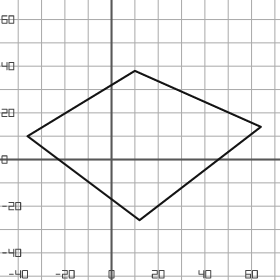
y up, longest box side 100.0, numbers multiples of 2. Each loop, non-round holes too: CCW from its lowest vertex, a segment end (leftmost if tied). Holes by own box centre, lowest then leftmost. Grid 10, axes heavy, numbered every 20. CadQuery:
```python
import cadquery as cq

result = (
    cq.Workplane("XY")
    .moveTo(12.0, -26.0)
    .lineTo(64.0, 14.0)
    .lineTo(10.0, 38.0)
    .lineTo(-36.0, 10.0)
    .close()
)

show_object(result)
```